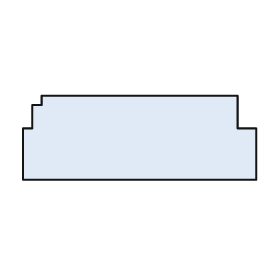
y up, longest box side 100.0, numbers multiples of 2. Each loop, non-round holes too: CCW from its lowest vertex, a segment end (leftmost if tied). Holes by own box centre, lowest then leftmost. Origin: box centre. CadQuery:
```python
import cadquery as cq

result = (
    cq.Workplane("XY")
    .moveTo(-50.0, -18.0)
    .lineTo(50.0, -18.0)
    .lineTo(50.0, 4.0)
    .lineTo(42.0, 4.0)
    .lineTo(42.0, 18.0)
    .lineTo(-42.0, 18.0)
    .lineTo(-42.0, 14.0)
    .lineTo(-46.0, 14.0)
    .lineTo(-46.0, 4.0)
    .lineTo(-50.0, 4.0)
    .close()
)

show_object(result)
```